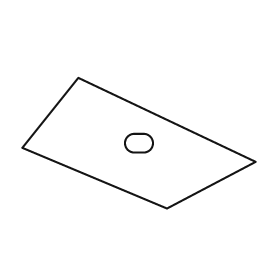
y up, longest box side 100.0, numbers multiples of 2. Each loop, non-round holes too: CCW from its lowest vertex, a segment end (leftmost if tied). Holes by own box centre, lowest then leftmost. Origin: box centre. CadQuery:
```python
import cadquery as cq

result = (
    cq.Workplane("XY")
    .moveTo(12.0, -28.0)
    .lineTo(50.0, -8.0)
    .lineTo(-26.0, 28.0)
    .lineTo(-50.0, -2.0)
    .close()
    .moveTo(-2.0, -4.0)
    .lineTo(2.0, -4.0)
    .threePointArc((6.0, 0.0), (2.0, 4.0))
    .lineTo(-2.0, 4.0)
    .threePointArc((-6.0, 0.0), (-2.0, -4.0))
    .close()
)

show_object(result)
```